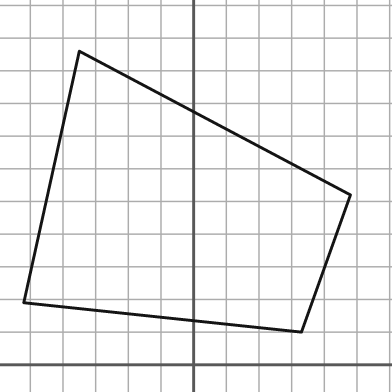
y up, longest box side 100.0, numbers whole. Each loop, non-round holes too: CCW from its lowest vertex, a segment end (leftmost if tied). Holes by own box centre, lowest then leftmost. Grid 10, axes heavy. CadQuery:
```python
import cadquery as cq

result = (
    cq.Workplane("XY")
    .moveTo(33.0, 10.0)
    .lineTo(48.0, 52.0)
    .lineTo(-35.0, 96.0)
    .lineTo(-52.0, 19.0)
    .close()
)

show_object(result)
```